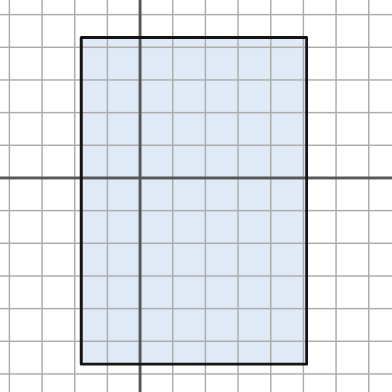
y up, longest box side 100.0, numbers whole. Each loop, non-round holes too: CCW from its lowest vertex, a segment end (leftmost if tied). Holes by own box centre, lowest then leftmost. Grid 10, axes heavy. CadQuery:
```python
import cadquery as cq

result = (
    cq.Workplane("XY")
    .moveTo(-18.0, -57.0)
    .lineTo(51.0, -57.0)
    .lineTo(51.0, 43.0)
    .lineTo(-18.0, 43.0)
    .close()
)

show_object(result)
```